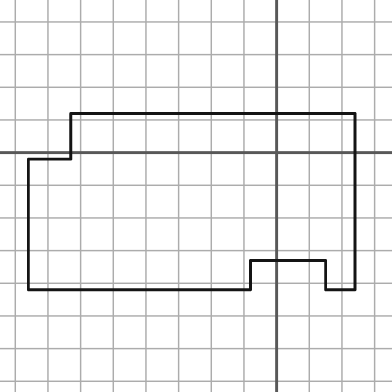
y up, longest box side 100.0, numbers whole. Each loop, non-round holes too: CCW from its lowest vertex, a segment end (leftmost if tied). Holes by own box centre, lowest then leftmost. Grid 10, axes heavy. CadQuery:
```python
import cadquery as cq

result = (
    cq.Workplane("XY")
    .moveTo(-76.0, -42.0)
    .lineTo(-8.0, -42.0)
    .lineTo(-8.0, -33.0)
    .lineTo(15.0, -33.0)
    .lineTo(15.0, -42.0)
    .lineTo(24.0, -42.0)
    .lineTo(24.0, 12.0)
    .lineTo(-63.0, 12.0)
    .lineTo(-63.0, -2.0)
    .lineTo(-76.0, -2.0)
    .close()
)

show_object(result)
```